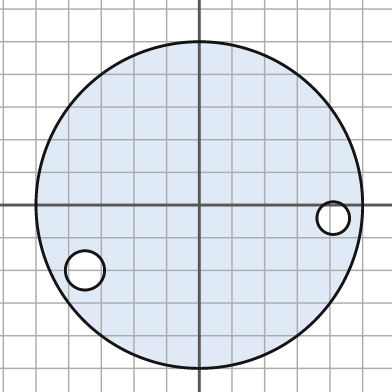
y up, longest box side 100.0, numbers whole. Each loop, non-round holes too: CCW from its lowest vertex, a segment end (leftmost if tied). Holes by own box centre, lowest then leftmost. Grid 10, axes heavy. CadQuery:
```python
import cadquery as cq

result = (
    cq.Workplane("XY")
    .moveTo(0.0, 0.0)
    .circle(50.0)
    .moveTo(-35.0, -20.0)
    .circle(6.0)
    .moveTo(41.0, -4.0)
    .circle(5.0)
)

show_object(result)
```